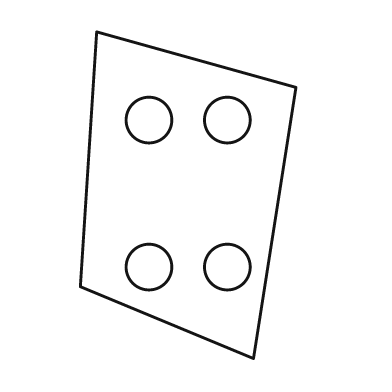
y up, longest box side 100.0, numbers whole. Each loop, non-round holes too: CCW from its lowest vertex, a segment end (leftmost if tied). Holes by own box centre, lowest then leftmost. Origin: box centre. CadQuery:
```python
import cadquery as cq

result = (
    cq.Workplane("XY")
    .moveTo(20.0, -50.0)
    .lineTo(33.0, 33.0)
    .lineTo(-28.0, 50.0)
    .lineTo(-33.0, -28.0)
    .close()
    .moveTo(-12.0, -22.0)
    .circle(7.0)
    .moveTo(12.0, -22.0)
    .circle(7.0)
    .moveTo(-12.0, 23.0)
    .circle(7.0)
    .moveTo(12.0, 23.0)
    .circle(7.0)
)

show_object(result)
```